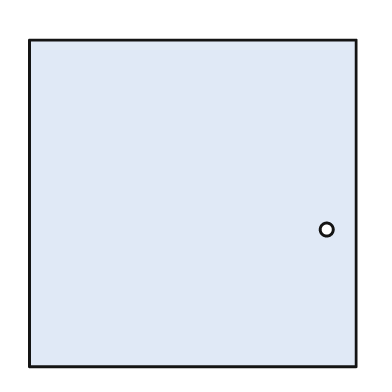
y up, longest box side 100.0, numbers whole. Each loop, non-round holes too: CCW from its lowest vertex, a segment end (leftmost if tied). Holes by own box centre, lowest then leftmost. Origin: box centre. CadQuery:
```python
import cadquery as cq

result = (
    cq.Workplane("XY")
    .moveTo(-50.0, -50.0)
    .lineTo(50.0, -50.0)
    .lineTo(50.0, 50.0)
    .lineTo(-50.0, 50.0)
    .close()
    .moveTo(41.0, -8.0)
    .circle(2.0)
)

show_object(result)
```